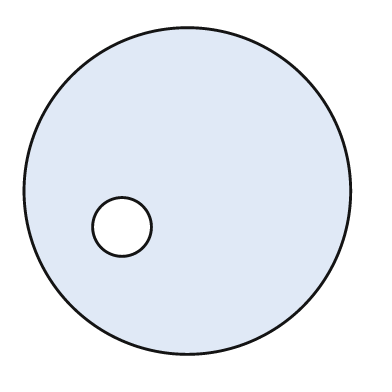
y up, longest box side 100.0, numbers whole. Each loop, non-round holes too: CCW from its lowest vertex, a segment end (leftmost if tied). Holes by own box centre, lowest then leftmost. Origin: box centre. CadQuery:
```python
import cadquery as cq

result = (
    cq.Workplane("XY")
    .moveTo(0.0, 0.0)
    .circle(50.0)
    .moveTo(-20.0, -11.0)
    .circle(9.0)
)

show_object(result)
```